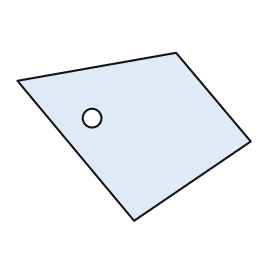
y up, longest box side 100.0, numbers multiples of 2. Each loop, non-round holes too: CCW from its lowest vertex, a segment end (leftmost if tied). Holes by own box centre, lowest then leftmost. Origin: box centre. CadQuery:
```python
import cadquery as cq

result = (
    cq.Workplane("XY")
    .moveTo(0.0, -36.0)
    .lineTo(50.0, -2.0)
    .lineTo(18.0, 36.0)
    .lineTo(-50.0, 24.0)
    .close()
    .moveTo(-18.0, 8.0)
    .circle(4.0)
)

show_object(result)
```